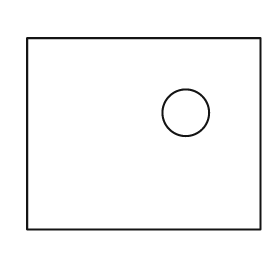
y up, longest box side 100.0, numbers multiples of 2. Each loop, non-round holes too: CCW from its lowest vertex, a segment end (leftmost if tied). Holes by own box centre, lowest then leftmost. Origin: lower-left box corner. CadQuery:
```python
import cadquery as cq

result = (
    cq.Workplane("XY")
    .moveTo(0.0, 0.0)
    .lineTo(100.0, 0.0)
    .lineTo(100.0, 82.0)
    .lineTo(0.0, 82.0)
    .close()
    .moveTo(68.0, 50.0)
    .circle(10.0)
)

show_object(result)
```